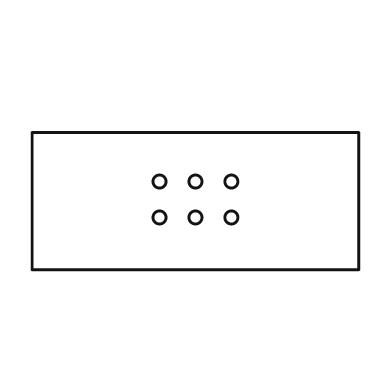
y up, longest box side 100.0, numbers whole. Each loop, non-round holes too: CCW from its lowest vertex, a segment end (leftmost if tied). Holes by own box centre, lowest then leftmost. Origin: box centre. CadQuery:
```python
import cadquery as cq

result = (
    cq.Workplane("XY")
    .moveTo(-50.0, -21.0)
    .lineTo(50.0, -21.0)
    .lineTo(50.0, 21.0)
    .lineTo(-50.0, 21.0)
    .close()
    .moveTo(-11.0, -5.0)
    .circle(2.0)
    .moveTo(0.0, -5.0)
    .circle(2.0)
    .moveTo(11.0, -5.0)
    .circle(2.0)
    .moveTo(-11.0, 6.0)
    .circle(2.0)
    .moveTo(0.0, 6.0)
    .circle(2.0)
    .moveTo(11.0, 6.0)
    .circle(2.0)
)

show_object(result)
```